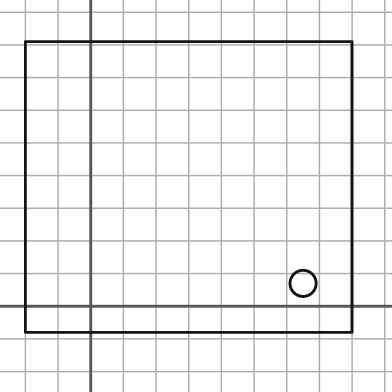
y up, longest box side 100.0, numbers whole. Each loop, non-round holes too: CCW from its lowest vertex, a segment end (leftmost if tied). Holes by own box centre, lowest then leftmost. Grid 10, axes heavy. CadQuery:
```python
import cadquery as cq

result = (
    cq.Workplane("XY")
    .moveTo(-20.0, -8.0)
    .lineTo(80.0, -8.0)
    .lineTo(80.0, 81.0)
    .lineTo(-20.0, 81.0)
    .close()
    .moveTo(65.0, 7.0)
    .circle(4.0)
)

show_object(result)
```